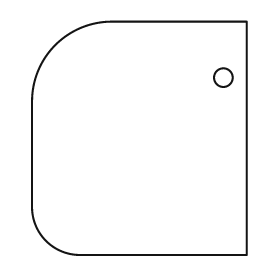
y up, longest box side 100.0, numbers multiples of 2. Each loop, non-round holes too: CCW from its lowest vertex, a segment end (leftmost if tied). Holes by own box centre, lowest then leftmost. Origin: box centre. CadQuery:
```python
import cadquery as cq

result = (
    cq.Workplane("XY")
    .moveTo(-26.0, -50.0)
    .lineTo(46.0, -50.0)
    .lineTo(46.0, 50.0)
    .lineTo(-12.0, 50.0)
    .threePointArc((-36.0, 40.0), (-46.0, 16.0))
    .lineTo(-46.0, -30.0)
    .threePointArc((-40.0, -44.0), (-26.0, -50.0))
    .close()
    .moveTo(36.0, 26.0)
    .circle(4.0)
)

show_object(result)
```